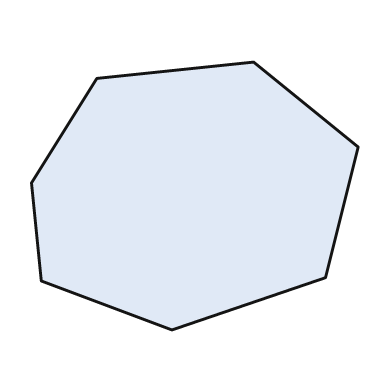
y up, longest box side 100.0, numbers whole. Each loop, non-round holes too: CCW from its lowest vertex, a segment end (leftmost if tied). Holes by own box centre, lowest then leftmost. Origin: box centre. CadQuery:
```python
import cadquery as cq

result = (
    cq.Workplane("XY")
    .moveTo(-7.0, -41.0)
    .lineTo(40.0, -25.0)
    .lineTo(50.0, 15.0)
    .lineTo(18.0, 41.0)
    .lineTo(-30.0, 36.0)
    .lineTo(-50.0, 4.0)
    .lineTo(-47.0, -26.0)
    .close()
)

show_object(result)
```